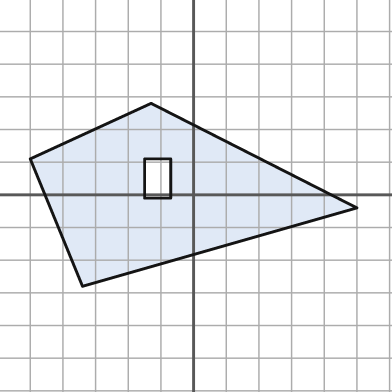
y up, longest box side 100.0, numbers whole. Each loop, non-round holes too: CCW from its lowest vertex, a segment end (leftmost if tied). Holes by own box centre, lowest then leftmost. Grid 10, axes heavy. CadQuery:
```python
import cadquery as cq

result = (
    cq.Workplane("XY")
    .moveTo(-34.0, -28.0)
    .lineTo(50.0, -4.0)
    .lineTo(-13.0, 28.0)
    .lineTo(-50.0, 11.0)
    .close()
    .moveTo(-15.0, -1.0)
    .lineTo(-7.0, -1.0)
    .lineTo(-7.0, 11.0)
    .lineTo(-15.0, 11.0)
    .close()
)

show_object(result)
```